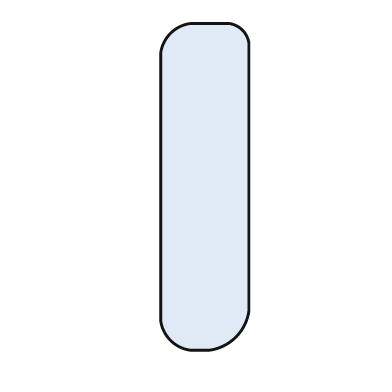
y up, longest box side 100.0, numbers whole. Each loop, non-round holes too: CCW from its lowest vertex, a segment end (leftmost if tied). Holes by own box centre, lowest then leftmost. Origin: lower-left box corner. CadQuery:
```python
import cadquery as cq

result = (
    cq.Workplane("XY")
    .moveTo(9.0, 0.0)
    .lineTo(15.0, 0.0)
    .threePointArc((23.0, 4.0), (27.0, 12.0))
    .lineTo(27.0, 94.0)
    .threePointArc((25.0, 98.0), (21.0, 100.0))
    .lineTo(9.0, 100.0)
    .threePointArc((3.0, 97.0), (0.0, 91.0))
    .lineTo(0.0, 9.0)
    .threePointArc((3.0, 3.0), (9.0, 0.0))
    .close()
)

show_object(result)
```